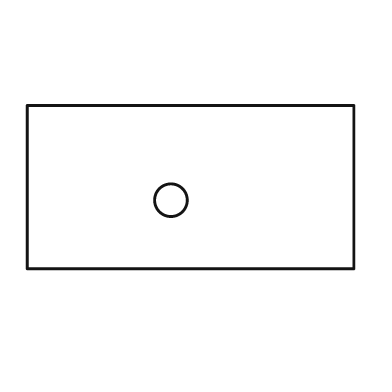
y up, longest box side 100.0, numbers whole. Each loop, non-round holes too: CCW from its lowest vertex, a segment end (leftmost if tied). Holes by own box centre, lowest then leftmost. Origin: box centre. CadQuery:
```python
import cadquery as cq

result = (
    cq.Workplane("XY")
    .moveTo(-50.0, -25.0)
    .lineTo(50.0, -25.0)
    .lineTo(50.0, 25.0)
    .lineTo(-50.0, 25.0)
    .close()
    .moveTo(-6.0, -4.0)
    .circle(5.0)
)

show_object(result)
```